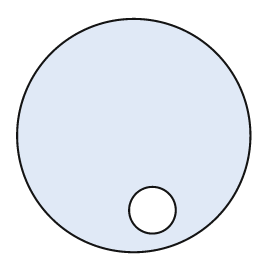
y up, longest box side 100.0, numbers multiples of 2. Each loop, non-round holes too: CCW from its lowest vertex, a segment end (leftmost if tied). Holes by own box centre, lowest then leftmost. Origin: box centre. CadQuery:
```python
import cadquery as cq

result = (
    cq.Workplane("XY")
    .moveTo(0.0, 0.0)
    .circle(50.0)
    .moveTo(8.0, -32.0)
    .circle(10.0)
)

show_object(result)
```